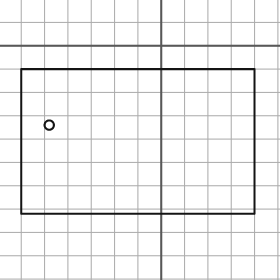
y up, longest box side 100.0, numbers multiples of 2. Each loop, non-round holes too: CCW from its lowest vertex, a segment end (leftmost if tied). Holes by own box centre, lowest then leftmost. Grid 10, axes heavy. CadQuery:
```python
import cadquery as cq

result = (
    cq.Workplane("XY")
    .moveTo(-60.0, -72.0)
    .lineTo(40.0, -72.0)
    .lineTo(40.0, -10.0)
    .lineTo(-60.0, -10.0)
    .close()
    .moveTo(-48.0, -34.0)
    .circle(2.0)
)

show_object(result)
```